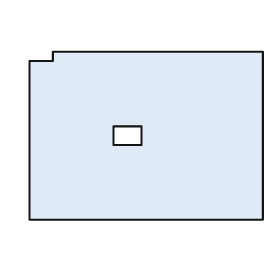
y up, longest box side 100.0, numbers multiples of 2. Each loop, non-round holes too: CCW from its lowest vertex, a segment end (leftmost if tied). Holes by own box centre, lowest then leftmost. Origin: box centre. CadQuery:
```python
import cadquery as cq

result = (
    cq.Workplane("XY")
    .moveTo(-50.0, -36.0)
    .lineTo(50.0, -36.0)
    .lineTo(50.0, 36.0)
    .lineTo(-40.0, 36.0)
    .lineTo(-40.0, 32.0)
    .lineTo(-50.0, 32.0)
    .close()
    .moveTo(-14.0, -4.0)
    .lineTo(-2.0, -4.0)
    .lineTo(-2.0, 4.0)
    .lineTo(-14.0, 4.0)
    .close()
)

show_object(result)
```